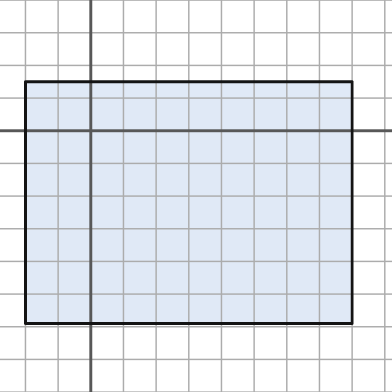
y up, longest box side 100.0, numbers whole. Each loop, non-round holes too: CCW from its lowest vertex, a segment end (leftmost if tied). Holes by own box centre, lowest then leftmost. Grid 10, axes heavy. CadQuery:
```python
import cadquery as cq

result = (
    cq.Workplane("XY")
    .moveTo(-20.0, -59.0)
    .lineTo(80.0, -59.0)
    .lineTo(80.0, 15.0)
    .lineTo(-20.0, 15.0)
    .close()
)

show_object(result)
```